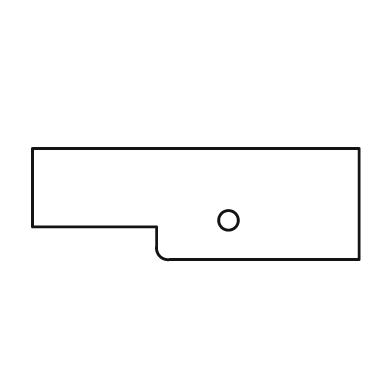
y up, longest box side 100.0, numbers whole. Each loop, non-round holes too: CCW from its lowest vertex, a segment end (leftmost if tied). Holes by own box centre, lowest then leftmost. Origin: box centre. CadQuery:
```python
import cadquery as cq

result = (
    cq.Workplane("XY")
    .moveTo(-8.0, -17.0)
    .lineTo(50.0, -17.0)
    .lineTo(50.0, 17.0)
    .lineTo(-50.0, 17.0)
    .lineTo(-50.0, -7.0)
    .lineTo(-12.0, -7.0)
    .lineTo(-12.0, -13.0)
    .threePointArc((-11.0, -16.0), (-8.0, -17.0))
    .close()
    .moveTo(10.0, -5.0)
    .circle(3.0)
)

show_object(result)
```